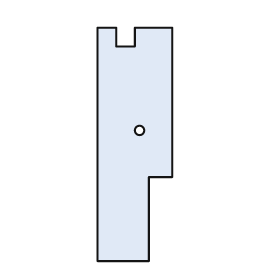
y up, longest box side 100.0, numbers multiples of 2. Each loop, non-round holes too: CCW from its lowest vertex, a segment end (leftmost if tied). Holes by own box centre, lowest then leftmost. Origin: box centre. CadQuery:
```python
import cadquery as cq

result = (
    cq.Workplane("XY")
    .moveTo(-16.0, -50.0)
    .lineTo(6.0, -50.0)
    .lineTo(6.0, -14.0)
    .lineTo(16.0, -14.0)
    .lineTo(16.0, 50.0)
    .lineTo(0.0, 50.0)
    .lineTo(0.0, 42.0)
    .lineTo(-8.0, 42.0)
    .lineTo(-8.0, 50.0)
    .lineTo(-16.0, 50.0)
    .close()
    .moveTo(2.0, 6.0)
    .circle(2.0)
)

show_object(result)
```